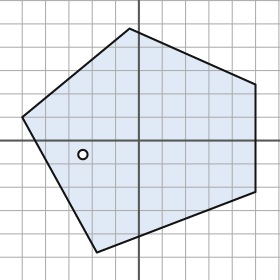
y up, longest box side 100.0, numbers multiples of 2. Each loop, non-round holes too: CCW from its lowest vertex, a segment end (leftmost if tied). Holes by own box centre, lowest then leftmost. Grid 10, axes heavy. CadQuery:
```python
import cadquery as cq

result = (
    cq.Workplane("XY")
    .moveTo(-18.0, -48.0)
    .lineTo(50.0, -22.0)
    .lineTo(50.0, 24.0)
    .lineTo(-4.0, 48.0)
    .lineTo(-50.0, 10.0)
    .close()
    .moveTo(-24.0, -6.0)
    .circle(2.0)
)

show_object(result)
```